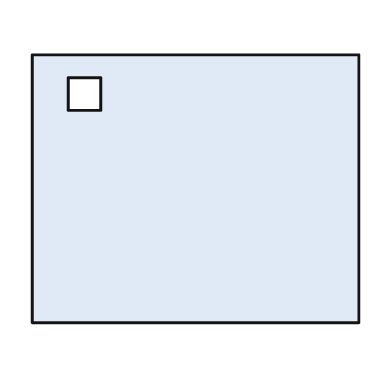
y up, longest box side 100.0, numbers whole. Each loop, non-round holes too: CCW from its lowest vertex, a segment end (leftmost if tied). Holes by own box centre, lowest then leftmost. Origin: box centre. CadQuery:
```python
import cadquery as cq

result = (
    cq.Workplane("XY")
    .moveTo(-50.0, -41.0)
    .lineTo(50.0, -41.0)
    .lineTo(50.0, 41.0)
    .lineTo(-50.0, 41.0)
    .close()
    .moveTo(-39.0, 24.0)
    .lineTo(-29.0, 24.0)
    .lineTo(-29.0, 34.0)
    .lineTo(-39.0, 34.0)
    .close()
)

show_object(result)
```